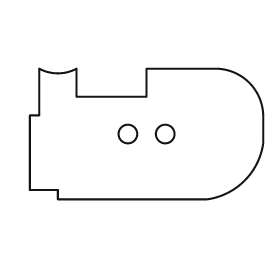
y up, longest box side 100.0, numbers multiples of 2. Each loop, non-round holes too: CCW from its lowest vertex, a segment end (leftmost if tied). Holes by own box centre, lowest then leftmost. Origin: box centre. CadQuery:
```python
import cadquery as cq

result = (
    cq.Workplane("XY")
    .moveTo(-38.0, -28.0)
    .lineTo(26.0, -28.0)
    .threePointArc((42.0, -20.0), (50.0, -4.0))
    .lineTo(50.0, 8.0)
    .threePointArc((44.0, 22.0), (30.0, 28.0))
    .lineTo(0.0, 28.0)
    .lineTo(0.0, 16.0)
    .lineTo(-30.0, 16.0)
    .lineTo(-30.0, 28.0)
    .threePointArc((-38.0, 26.0), (-46.0, 28.0))
    .lineTo(-46.0, 8.0)
    .lineTo(-50.0, 8.0)
    .lineTo(-50.0, -24.0)
    .lineTo(-38.0, -24.0)
    .close()
    .moveTo(-8.0, 0.0)
    .circle(4.0)
    .moveTo(8.0, 0.0)
    .circle(4.0)
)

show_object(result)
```